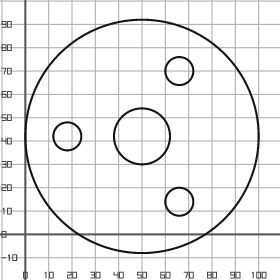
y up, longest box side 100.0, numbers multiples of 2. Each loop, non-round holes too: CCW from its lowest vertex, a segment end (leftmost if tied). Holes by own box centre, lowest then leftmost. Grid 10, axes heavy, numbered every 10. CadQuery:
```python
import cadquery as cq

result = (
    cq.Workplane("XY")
    .moveTo(50.0, 42.0)
    .circle(50.0)
    .moveTo(66.0, 14.0)
    .circle(6.0)
    .moveTo(18.0, 42.0)
    .circle(6.0)
    .moveTo(50.0, 42.0)
    .circle(12.0)
    .moveTo(66.0, 70.0)
    .circle(6.0)
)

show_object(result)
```